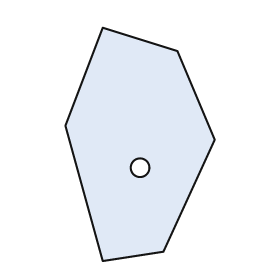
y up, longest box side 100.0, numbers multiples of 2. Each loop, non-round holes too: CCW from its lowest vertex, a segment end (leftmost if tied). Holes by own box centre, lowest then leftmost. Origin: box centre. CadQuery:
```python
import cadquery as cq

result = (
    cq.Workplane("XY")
    .moveTo(-16.0, -50.0)
    .lineTo(10.0, -46.0)
    .lineTo(32.0, 2.0)
    .lineTo(16.0, 40.0)
    .lineTo(-16.0, 50.0)
    .lineTo(-32.0, 8.0)
    .close()
    .moveTo(0.0, -10.0)
    .circle(4.0)
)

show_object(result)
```